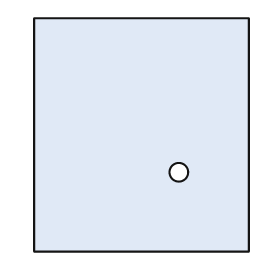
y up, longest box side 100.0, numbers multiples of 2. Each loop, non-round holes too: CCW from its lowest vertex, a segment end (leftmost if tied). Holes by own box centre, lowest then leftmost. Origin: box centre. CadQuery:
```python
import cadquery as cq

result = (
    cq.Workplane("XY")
    .moveTo(-46.0, -50.0)
    .lineTo(46.0, -50.0)
    .lineTo(46.0, 50.0)
    .lineTo(-46.0, 50.0)
    .close()
    .moveTo(16.0, -16.0)
    .circle(4.0)
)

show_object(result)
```